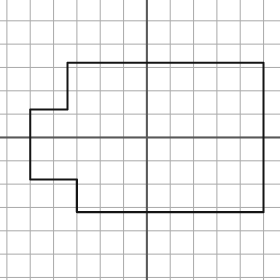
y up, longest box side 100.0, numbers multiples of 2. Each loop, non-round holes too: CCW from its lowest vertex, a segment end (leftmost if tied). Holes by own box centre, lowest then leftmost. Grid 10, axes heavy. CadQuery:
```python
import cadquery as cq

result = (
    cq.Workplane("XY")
    .moveTo(-30.0, -32.0)
    .lineTo(50.0, -32.0)
    .lineTo(50.0, 32.0)
    .lineTo(-34.0, 32.0)
    .lineTo(-34.0, 12.0)
    .lineTo(-50.0, 12.0)
    .lineTo(-50.0, -18.0)
    .lineTo(-30.0, -18.0)
    .close()
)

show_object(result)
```